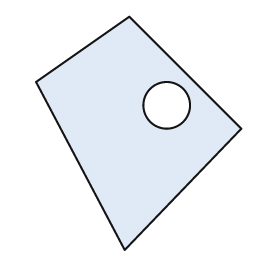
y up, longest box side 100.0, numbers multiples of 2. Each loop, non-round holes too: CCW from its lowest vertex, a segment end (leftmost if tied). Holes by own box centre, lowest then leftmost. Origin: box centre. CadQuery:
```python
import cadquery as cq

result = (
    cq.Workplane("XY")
    .moveTo(-6.0, -50.0)
    .lineTo(44.0, 2.0)
    .lineTo(-4.0, 50.0)
    .lineTo(-44.0, 22.0)
    .close()
    .moveTo(12.0, 12.0)
    .circle(10.0)
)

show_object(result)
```